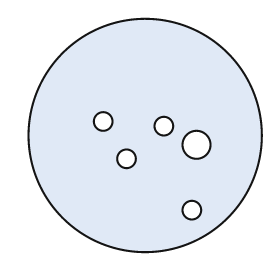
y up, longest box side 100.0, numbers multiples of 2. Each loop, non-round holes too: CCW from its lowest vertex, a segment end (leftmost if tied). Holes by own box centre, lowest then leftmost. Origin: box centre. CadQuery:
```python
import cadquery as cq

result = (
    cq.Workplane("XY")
    .moveTo(0.0, 0.0)
    .circle(50.0)
    .moveTo(20.0, -32.0)
    .circle(4.0)
    .moveTo(-8.0, -10.0)
    .circle(4.0)
    .moveTo(22.0, -4.0)
    .circle(6.0)
    .moveTo(8.0, 4.0)
    .circle(4.0)
    .moveTo(-18.0, 6.0)
    .circle(4.0)
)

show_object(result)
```